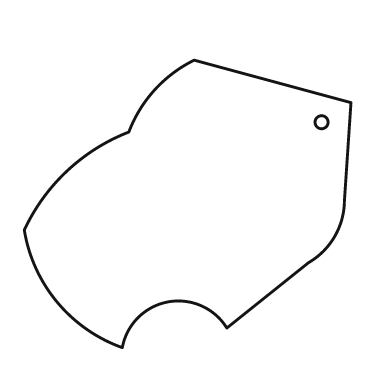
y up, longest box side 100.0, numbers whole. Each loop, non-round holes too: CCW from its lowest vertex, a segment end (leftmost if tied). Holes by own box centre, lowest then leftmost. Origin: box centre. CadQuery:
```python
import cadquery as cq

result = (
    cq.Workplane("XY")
    .moveTo(-20.0, -44.0)
    .threePointArc((-6.0, -30.0), (12.0, -38.0))
    .lineTo(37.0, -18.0)
    .threePointArc((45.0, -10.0), (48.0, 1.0))
    .lineTo(50.0, 31.0)
    .lineTo(2.0, 44.0)
    .threePointArc((-10.0, 35.0), (-18.0, 22.0))
    .threePointArc((-37.0, 10.0), (-50.0, -8.0))
    .threePointArc((-40.0, -30.0), (-20.0, -44.0))
    .close()
    .moveTo(41.0, 25.0)
    .circle(2.0)
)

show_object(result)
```